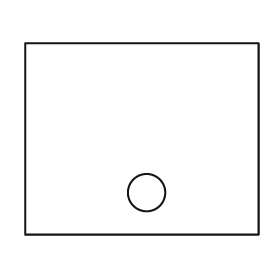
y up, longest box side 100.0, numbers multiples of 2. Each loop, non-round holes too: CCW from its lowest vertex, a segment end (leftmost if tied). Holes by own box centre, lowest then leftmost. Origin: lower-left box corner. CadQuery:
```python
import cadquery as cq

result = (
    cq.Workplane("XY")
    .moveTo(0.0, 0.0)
    .lineTo(100.0, 0.0)
    .lineTo(100.0, 82.0)
    .lineTo(0.0, 82.0)
    .close()
    .moveTo(52.0, 18.0)
    .circle(8.0)
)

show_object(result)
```